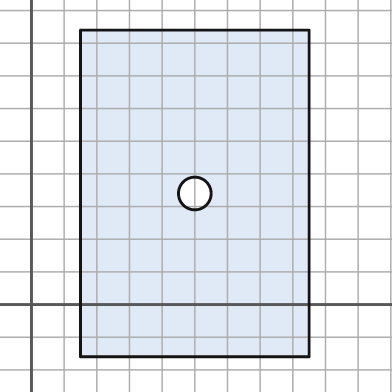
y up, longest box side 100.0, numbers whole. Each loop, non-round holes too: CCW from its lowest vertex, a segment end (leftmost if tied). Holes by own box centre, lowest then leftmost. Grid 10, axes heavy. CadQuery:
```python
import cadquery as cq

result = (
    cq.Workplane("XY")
    .moveTo(15.0, -16.0)
    .lineTo(85.0, -16.0)
    .lineTo(85.0, 84.0)
    .lineTo(15.0, 84.0)
    .close()
    .moveTo(50.0, 34.0)
    .circle(5.0)
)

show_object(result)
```